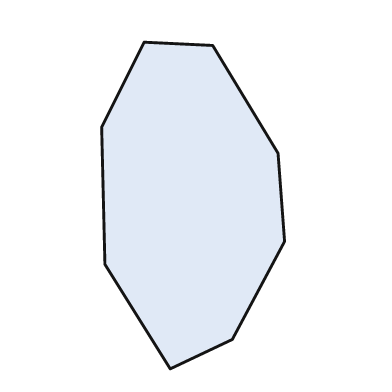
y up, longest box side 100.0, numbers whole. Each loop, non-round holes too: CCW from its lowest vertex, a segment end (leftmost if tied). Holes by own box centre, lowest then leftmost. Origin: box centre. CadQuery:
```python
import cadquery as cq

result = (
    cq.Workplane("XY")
    .moveTo(-7.0, -50.0)
    .lineTo(12.0, -41.0)
    .lineTo(28.0, -11.0)
    .lineTo(26.0, 16.0)
    .lineTo(6.0, 49.0)
    .lineTo(-15.0, 50.0)
    .lineTo(-28.0, 24.0)
    .lineTo(-27.0, -18.0)
    .close()
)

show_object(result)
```